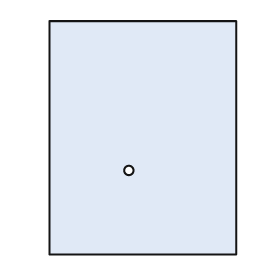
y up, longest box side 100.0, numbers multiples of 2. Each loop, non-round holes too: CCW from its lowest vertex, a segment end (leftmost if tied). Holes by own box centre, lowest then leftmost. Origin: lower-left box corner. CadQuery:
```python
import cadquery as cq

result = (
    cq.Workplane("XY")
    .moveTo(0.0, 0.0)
    .lineTo(80.0, 0.0)
    .lineTo(80.0, 100.0)
    .lineTo(0.0, 100.0)
    .close()
    .moveTo(34.0, 36.0)
    .circle(2.0)
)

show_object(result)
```